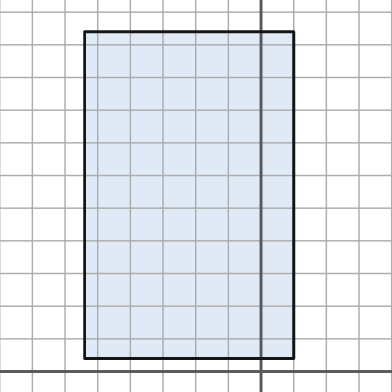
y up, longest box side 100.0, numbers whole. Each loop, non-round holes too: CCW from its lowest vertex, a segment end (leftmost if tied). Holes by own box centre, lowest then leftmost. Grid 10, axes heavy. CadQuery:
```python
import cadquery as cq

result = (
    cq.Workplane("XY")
    .moveTo(-54.0, 4.0)
    .lineTo(10.0, 4.0)
    .lineTo(10.0, 104.0)
    .lineTo(-54.0, 104.0)
    .close()
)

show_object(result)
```